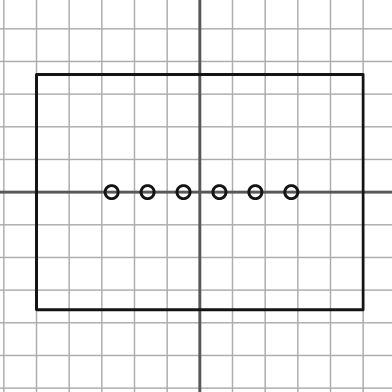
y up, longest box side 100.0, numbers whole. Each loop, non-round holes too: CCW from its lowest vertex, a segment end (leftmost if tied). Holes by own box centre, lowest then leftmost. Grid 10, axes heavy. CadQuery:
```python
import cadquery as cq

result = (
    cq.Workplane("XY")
    .moveTo(-50.0, -36.0)
    .lineTo(50.0, -36.0)
    .lineTo(50.0, 36.0)
    .lineTo(-50.0, 36.0)
    .close()
    .moveTo(-27.0, 0.0)
    .circle(2.0)
    .moveTo(-16.0, 0.0)
    .circle(2.0)
    .moveTo(-5.0, 0.0)
    .circle(2.0)
    .moveTo(6.0, 0.0)
    .circle(2.0)
    .moveTo(17.0, 0.0)
    .circle(2.0)
    .moveTo(28.0, 0.0)
    .circle(2.0)
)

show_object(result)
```